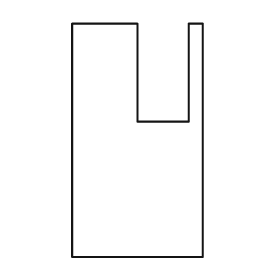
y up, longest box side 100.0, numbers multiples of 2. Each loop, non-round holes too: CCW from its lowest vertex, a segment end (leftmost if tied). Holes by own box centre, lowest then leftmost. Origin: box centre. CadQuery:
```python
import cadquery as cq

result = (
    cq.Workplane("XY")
    .moveTo(-28.0, -50.0)
    .lineTo(28.0, -50.0)
    .lineTo(28.0, 50.0)
    .lineTo(22.0, 50.0)
    .lineTo(22.0, 8.0)
    .lineTo(0.0, 8.0)
    .lineTo(0.0, 50.0)
    .lineTo(-28.0, 50.0)
    .close()
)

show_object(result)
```